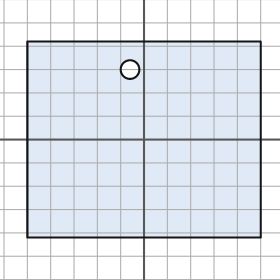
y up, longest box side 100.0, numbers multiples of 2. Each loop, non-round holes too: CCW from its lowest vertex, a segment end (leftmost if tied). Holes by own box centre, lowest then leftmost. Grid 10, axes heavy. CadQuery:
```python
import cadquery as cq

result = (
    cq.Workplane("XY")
    .moveTo(-50.0, -42.0)
    .lineTo(50.0, -42.0)
    .lineTo(50.0, 42.0)
    .lineTo(-50.0, 42.0)
    .close()
    .moveTo(-6.0, 30.0)
    .circle(4.0)
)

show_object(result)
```